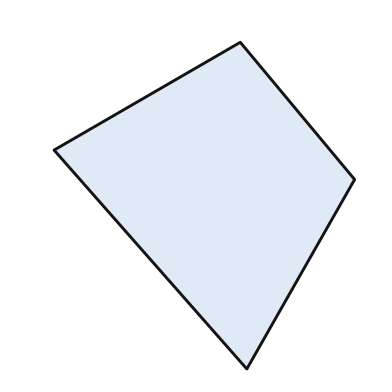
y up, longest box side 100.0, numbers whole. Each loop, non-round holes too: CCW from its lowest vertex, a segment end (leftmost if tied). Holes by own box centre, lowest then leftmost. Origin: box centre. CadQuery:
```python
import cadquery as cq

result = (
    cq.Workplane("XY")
    .moveTo(13.0, -50.0)
    .lineTo(46.0, 8.0)
    .lineTo(11.0, 50.0)
    .lineTo(-46.0, 17.0)
    .close()
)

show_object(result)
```